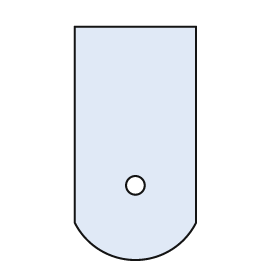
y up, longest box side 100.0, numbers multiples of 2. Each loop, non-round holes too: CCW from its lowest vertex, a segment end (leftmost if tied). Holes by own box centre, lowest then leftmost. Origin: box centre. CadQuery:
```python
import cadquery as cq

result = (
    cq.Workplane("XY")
    .moveTo(-26.0, -34.0)
    .threePointArc((0.0, -50.0), (26.0, -34.0))
    .lineTo(26.0, 50.0)
    .lineTo(-26.0, 50.0)
    .close()
    .moveTo(0.0, -18.0)
    .circle(4.0)
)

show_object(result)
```